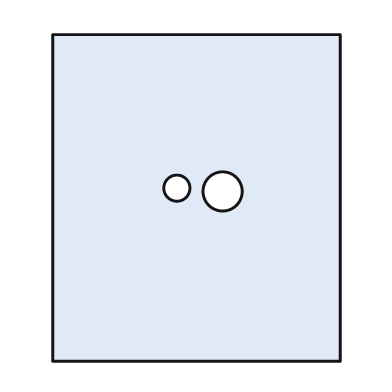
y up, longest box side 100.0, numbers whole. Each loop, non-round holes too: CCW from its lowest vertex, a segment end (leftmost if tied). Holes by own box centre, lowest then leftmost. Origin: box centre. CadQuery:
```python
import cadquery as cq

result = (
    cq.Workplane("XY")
    .moveTo(-44.0, -50.0)
    .lineTo(44.0, -50.0)
    .lineTo(44.0, 50.0)
    .lineTo(-44.0, 50.0)
    .close()
    .moveTo(8.0, 2.0)
    .circle(6.0)
    .moveTo(-6.0, 3.0)
    .circle(4.0)
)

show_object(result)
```